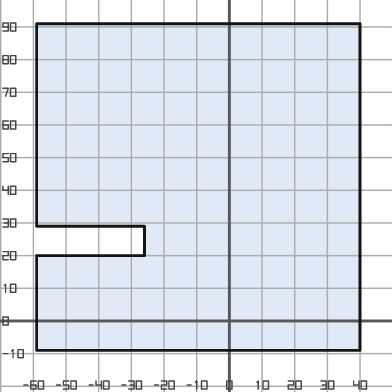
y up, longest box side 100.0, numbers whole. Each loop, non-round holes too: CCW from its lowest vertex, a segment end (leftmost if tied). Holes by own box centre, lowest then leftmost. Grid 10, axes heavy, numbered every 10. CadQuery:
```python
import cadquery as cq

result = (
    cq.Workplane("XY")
    .moveTo(-59.0, -9.0)
    .lineTo(40.0, -9.0)
    .lineTo(40.0, 91.0)
    .lineTo(-59.0, 91.0)
    .lineTo(-59.0, 29.0)
    .lineTo(-26.0, 29.0)
    .lineTo(-26.0, 20.0)
    .lineTo(-59.0, 20.0)
    .close()
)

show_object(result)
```